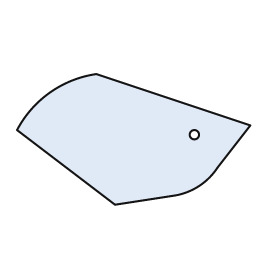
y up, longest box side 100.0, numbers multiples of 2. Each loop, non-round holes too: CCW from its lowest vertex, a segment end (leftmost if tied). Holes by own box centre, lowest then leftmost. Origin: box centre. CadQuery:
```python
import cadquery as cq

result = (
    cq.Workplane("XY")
    .moveTo(-8.0, -28.0)
    .lineTo(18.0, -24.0)
    .threePointArc((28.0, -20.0), (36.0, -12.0))
    .lineTo(50.0, 6.0)
    .lineTo(-16.0, 28.0)
    .threePointArc((-36.0, 20.0), (-50.0, 4.0))
    .close()
    .moveTo(26.0, 2.0)
    .circle(2.0)
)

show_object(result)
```